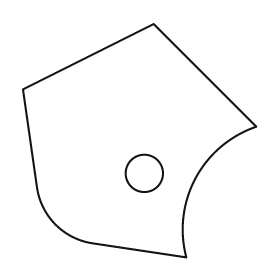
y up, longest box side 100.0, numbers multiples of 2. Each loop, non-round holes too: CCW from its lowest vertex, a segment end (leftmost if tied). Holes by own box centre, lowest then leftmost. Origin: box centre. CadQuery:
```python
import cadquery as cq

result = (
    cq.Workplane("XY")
    .moveTo(20.0, -50.0)
    .threePointArc((24.0, -16.0), (50.0, 6.0))
    .lineTo(6.0, 50.0)
    .lineTo(-50.0, 22.0)
    .lineTo(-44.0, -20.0)
    .threePointArc((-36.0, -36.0), (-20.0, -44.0))
    .close()
    .moveTo(2.0, -14.0)
    .circle(8.0)
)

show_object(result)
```